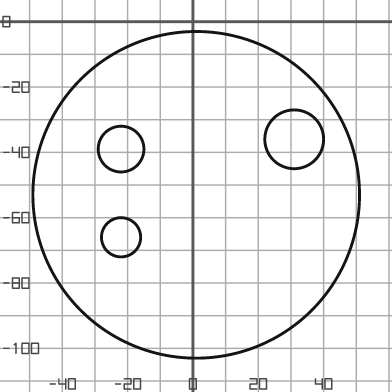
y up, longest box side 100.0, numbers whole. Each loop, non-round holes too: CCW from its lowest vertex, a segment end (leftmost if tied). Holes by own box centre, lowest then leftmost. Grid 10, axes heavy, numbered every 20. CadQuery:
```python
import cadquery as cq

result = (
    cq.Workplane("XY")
    .moveTo(1.0, -53.0)
    .circle(50.0)
    .moveTo(-22.0, -66.0)
    .circle(6.0)
    .moveTo(-22.0, -39.0)
    .circle(7.0)
    .moveTo(31.0, -36.0)
    .circle(9.0)
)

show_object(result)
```